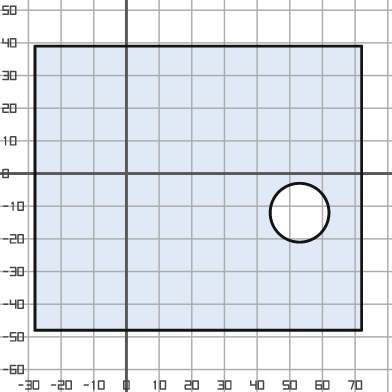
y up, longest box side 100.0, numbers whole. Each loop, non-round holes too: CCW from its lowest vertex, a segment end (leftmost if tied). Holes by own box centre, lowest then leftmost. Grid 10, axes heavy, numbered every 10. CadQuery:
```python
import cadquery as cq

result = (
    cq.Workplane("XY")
    .moveTo(-28.0, -48.0)
    .lineTo(72.0, -48.0)
    .lineTo(72.0, 39.0)
    .lineTo(-28.0, 39.0)
    .close()
    .moveTo(53.0, -12.0)
    .circle(9.0)
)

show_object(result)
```